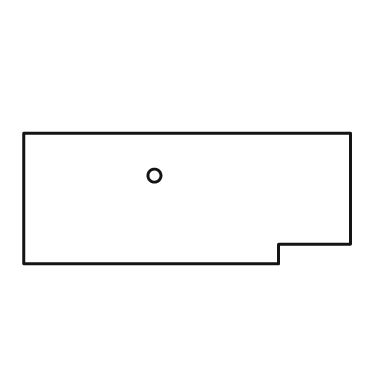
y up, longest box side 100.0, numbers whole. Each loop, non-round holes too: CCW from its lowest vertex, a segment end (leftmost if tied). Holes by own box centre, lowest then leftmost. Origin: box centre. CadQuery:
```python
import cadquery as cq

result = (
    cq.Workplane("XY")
    .moveTo(-50.0, -20.0)
    .lineTo(28.0, -20.0)
    .lineTo(28.0, -14.0)
    .lineTo(50.0, -14.0)
    .lineTo(50.0, 20.0)
    .lineTo(-50.0, 20.0)
    .close()
    .moveTo(-10.0, 7.0)
    .circle(2.0)
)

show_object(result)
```